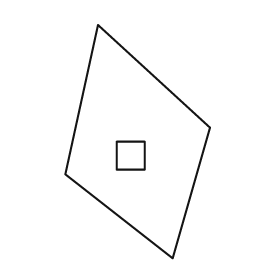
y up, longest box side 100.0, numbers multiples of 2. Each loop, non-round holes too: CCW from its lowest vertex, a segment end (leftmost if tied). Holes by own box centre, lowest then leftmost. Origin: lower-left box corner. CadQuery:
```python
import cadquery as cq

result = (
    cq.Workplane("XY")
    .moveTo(46.0, 0.0)
    .lineTo(62.0, 56.0)
    .lineTo(14.0, 100.0)
    .lineTo(0.0, 36.0)
    .close()
    .moveTo(22.0, 38.0)
    .lineTo(34.0, 38.0)
    .lineTo(34.0, 50.0)
    .lineTo(22.0, 50.0)
    .close()
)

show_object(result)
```